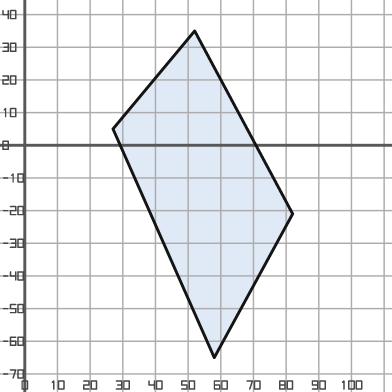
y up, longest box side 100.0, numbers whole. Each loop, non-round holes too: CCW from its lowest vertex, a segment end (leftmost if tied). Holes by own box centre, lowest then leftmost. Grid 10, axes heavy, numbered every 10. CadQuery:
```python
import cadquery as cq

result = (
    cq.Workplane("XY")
    .moveTo(58.0, -65.0)
    .lineTo(82.0, -21.0)
    .lineTo(52.0, 35.0)
    .lineTo(27.0, 5.0)
    .close()
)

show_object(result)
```